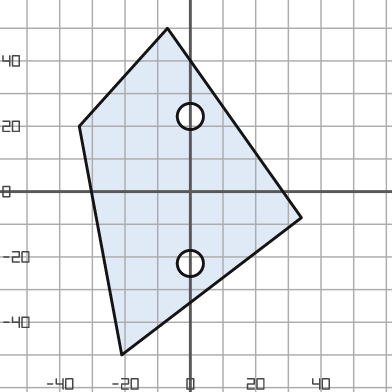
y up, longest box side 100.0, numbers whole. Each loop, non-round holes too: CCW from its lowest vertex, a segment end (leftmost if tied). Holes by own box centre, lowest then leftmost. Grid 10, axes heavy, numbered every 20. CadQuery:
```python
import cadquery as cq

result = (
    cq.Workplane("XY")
    .moveTo(-21.0, -50.0)
    .lineTo(34.0, -8.0)
    .lineTo(-7.0, 50.0)
    .lineTo(-34.0, 20.0)
    .close()
    .moveTo(0.0, -22.0)
    .circle(4.0)
    .moveTo(0.0, 23.0)
    .circle(4.0)
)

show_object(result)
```